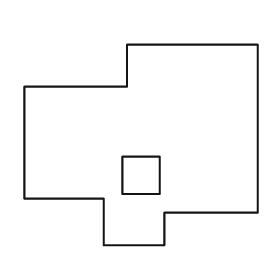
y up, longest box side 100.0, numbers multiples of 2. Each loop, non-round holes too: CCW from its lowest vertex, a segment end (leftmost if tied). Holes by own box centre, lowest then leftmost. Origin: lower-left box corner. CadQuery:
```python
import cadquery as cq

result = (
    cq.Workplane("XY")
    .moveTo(34.0, 0.0)
    .lineTo(60.0, 0.0)
    .lineTo(60.0, 14.0)
    .lineTo(100.0, 14.0)
    .lineTo(100.0, 86.0)
    .lineTo(44.0, 86.0)
    .lineTo(44.0, 68.0)
    .lineTo(0.0, 68.0)
    .lineTo(0.0, 20.0)
    .lineTo(34.0, 20.0)
    .close()
    .moveTo(42.0, 22.0)
    .lineTo(58.0, 22.0)
    .lineTo(58.0, 38.0)
    .lineTo(42.0, 38.0)
    .close()
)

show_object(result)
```